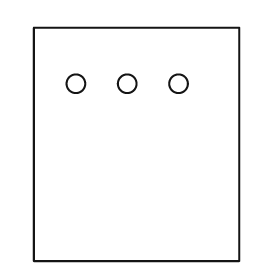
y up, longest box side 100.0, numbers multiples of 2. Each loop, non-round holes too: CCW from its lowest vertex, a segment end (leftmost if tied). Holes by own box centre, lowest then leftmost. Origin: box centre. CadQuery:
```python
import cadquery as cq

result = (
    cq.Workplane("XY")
    .moveTo(-44.0, -50.0)
    .lineTo(44.0, -50.0)
    .lineTo(44.0, 50.0)
    .lineTo(-44.0, 50.0)
    .close()
    .moveTo(-26.0, 26.0)
    .circle(4.0)
    .moveTo(-4.0, 26.0)
    .circle(4.0)
    .moveTo(18.0, 26.0)
    .circle(4.0)
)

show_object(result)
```